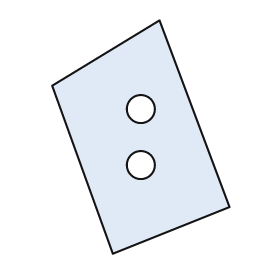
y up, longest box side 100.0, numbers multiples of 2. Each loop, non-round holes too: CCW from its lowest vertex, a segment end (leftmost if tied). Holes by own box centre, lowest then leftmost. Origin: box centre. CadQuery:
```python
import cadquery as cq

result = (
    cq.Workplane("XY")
    .moveTo(-12.0, -50.0)
    .lineTo(38.0, -30.0)
    .lineTo(8.0, 50.0)
    .lineTo(-38.0, 22.0)
    .close()
    .moveTo(0.0, -12.0)
    .circle(6.0)
    .moveTo(0.0, 12.0)
    .circle(6.0)
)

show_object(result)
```